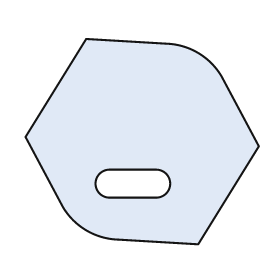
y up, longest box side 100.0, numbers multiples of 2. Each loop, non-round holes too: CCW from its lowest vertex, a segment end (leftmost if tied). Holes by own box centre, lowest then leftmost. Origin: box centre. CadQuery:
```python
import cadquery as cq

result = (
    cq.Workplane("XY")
    .moveTo(24.0, -44.0)
    .lineTo(50.0, -2.0)
    .lineTo(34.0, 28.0)
    .threePointArc((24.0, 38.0), (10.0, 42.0))
    .lineTo(-24.0, 44.0)
    .lineTo(-50.0, 2.0)
    .lineTo(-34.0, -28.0)
    .threePointArc((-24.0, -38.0), (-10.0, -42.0))
    .close()
    .moveTo(-14.0, -24.0)
    .lineTo(6.0, -24.0)
    .threePointArc((12.0, -18.0), (6.0, -12.0))
    .lineTo(-14.0, -12.0)
    .threePointArc((-20.0, -18.0), (-14.0, -24.0))
    .close()
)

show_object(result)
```